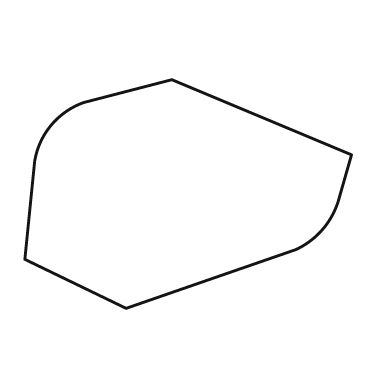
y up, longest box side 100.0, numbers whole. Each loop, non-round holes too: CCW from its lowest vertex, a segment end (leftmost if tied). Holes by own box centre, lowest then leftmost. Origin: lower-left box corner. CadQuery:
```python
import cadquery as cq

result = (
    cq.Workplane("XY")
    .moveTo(31.0, 0.0)
    .lineTo(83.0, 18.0)
    .threePointArc((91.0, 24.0), (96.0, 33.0))
    .lineTo(100.0, 47.0)
    .lineTo(45.0, 70.0)
    .lineTo(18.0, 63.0)
    .threePointArc((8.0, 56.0), (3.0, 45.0))
    .lineTo(0.0, 15.0)
    .close()
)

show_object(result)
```